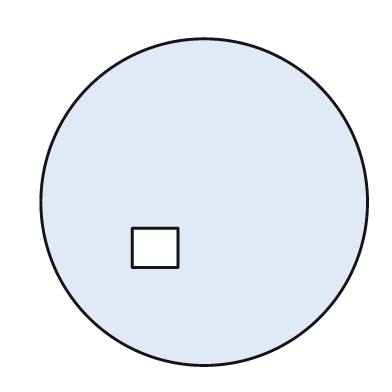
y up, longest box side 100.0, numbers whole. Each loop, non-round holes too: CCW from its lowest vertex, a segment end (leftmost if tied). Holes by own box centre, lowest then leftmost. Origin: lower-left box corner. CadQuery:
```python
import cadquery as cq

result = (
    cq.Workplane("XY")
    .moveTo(50.0, 50.0)
    .circle(50.0)
    .moveTo(28.0, 30.0)
    .lineTo(42.0, 30.0)
    .lineTo(42.0, 42.0)
    .lineTo(28.0, 42.0)
    .close()
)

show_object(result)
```